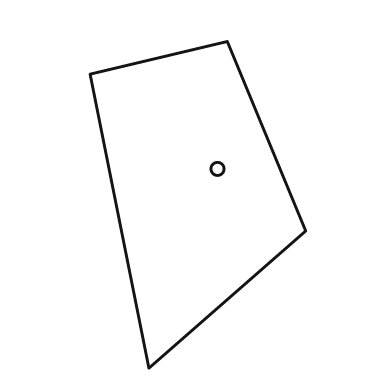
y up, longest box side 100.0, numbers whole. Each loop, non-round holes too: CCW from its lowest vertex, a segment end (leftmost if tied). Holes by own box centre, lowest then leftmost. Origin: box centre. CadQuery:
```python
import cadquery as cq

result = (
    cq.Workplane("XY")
    .moveTo(-15.0, -50.0)
    .lineTo(33.0, -8.0)
    .lineTo(9.0, 50.0)
    .lineTo(-33.0, 40.0)
    .close()
    .moveTo(6.0, 11.0)
    .circle(2.0)
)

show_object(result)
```